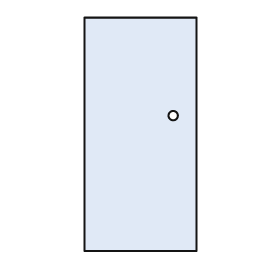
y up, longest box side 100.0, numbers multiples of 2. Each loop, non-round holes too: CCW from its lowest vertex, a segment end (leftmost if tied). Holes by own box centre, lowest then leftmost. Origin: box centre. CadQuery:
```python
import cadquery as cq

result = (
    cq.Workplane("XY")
    .moveTo(-24.0, -50.0)
    .lineTo(24.0, -50.0)
    .lineTo(24.0, 50.0)
    .lineTo(-24.0, 50.0)
    .close()
    .moveTo(14.0, 8.0)
    .circle(2.0)
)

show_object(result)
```